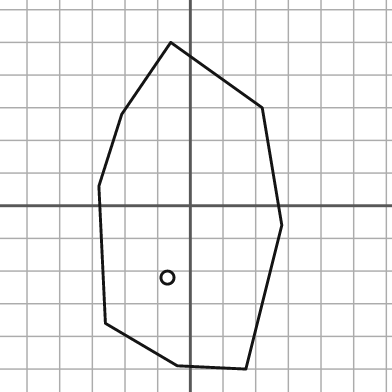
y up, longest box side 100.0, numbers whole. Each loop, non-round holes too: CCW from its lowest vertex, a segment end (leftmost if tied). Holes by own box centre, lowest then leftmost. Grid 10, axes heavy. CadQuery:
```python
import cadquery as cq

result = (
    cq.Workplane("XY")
    .moveTo(17.0, -50.0)
    .lineTo(28.0, -6.0)
    .lineTo(22.0, 30.0)
    .lineTo(-6.0, 50.0)
    .lineTo(-21.0, 28.0)
    .lineTo(-28.0, 6.0)
    .lineTo(-26.0, -36.0)
    .lineTo(-4.0, -49.0)
    .close()
    .moveTo(-7.0, -22.0)
    .circle(2.0)
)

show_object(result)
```